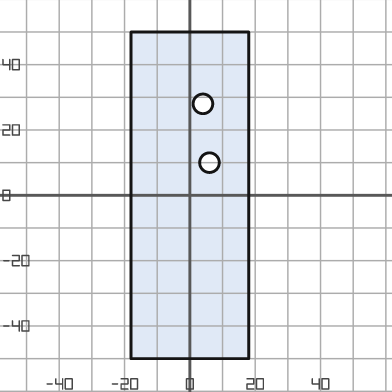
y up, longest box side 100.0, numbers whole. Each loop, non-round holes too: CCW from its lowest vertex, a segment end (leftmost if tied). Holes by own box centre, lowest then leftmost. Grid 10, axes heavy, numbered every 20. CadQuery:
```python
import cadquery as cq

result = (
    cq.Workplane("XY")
    .moveTo(-18.0, -50.0)
    .lineTo(18.0, -50.0)
    .lineTo(18.0, 50.0)
    .lineTo(-18.0, 50.0)
    .close()
    .moveTo(6.0, 10.0)
    .circle(3.0)
    .moveTo(4.0, 28.0)
    .circle(3.0)
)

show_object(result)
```